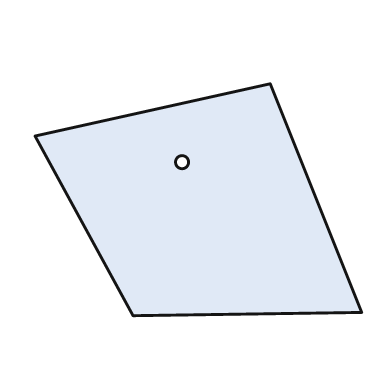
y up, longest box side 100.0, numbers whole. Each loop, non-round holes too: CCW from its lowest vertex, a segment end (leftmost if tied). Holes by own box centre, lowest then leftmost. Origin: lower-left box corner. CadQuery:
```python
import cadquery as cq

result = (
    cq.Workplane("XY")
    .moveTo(30.0, 0.0)
    .lineTo(100.0, 1.0)
    .lineTo(72.0, 71.0)
    .lineTo(0.0, 55.0)
    .close()
    .moveTo(45.0, 47.0)
    .circle(2.0)
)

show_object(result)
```